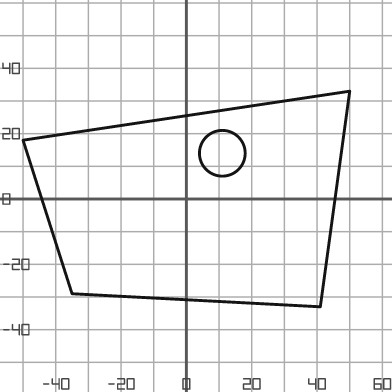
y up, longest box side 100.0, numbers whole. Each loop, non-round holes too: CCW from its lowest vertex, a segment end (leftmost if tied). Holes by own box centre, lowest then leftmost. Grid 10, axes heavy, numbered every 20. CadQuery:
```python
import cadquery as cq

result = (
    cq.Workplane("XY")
    .moveTo(41.0, -33.0)
    .lineTo(50.0, 33.0)
    .lineTo(-50.0, 18.0)
    .lineTo(-35.0, -29.0)
    .close()
    .moveTo(11.0, 14.0)
    .circle(7.0)
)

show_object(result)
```